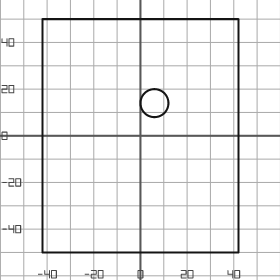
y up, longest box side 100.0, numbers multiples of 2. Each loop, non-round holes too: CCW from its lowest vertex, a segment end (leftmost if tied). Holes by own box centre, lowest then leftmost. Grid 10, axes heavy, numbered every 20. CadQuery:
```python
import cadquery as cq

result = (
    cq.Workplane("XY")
    .moveTo(-42.0, -50.0)
    .lineTo(42.0, -50.0)
    .lineTo(42.0, 50.0)
    .lineTo(-42.0, 50.0)
    .close()
    .moveTo(6.0, 14.0)
    .circle(6.0)
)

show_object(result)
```